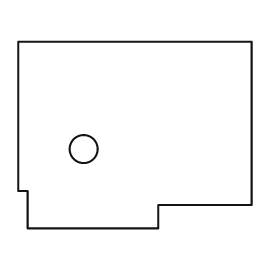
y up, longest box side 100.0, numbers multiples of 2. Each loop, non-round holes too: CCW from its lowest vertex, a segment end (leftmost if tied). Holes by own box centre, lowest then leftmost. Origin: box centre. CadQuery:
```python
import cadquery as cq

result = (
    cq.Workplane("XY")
    .moveTo(-46.0, -40.0)
    .lineTo(10.0, -40.0)
    .lineTo(10.0, -30.0)
    .lineTo(50.0, -30.0)
    .lineTo(50.0, 40.0)
    .lineTo(-50.0, 40.0)
    .lineTo(-50.0, -24.0)
    .lineTo(-46.0, -24.0)
    .close()
    .moveTo(-22.0, -6.0)
    .circle(6.0)
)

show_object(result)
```